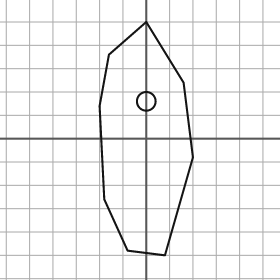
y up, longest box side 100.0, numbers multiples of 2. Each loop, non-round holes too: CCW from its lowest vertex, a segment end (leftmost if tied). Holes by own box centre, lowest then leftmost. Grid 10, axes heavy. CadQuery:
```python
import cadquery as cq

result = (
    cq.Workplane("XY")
    .moveTo(8.0, -50.0)
    .lineTo(20.0, -8.0)
    .lineTo(16.0, 24.0)
    .lineTo(0.0, 50.0)
    .lineTo(-16.0, 36.0)
    .lineTo(-20.0, 14.0)
    .lineTo(-18.0, -26.0)
    .lineTo(-8.0, -48.0)
    .close()
    .moveTo(0.0, 16.0)
    .circle(4.0)
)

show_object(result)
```